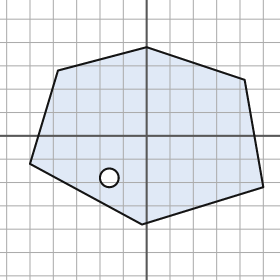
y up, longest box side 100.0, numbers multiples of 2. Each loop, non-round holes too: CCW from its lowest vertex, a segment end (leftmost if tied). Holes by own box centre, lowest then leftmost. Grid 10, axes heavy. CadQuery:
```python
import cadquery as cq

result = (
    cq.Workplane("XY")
    .moveTo(-2.0, -38.0)
    .lineTo(50.0, -22.0)
    .lineTo(42.0, 24.0)
    .lineTo(0.0, 38.0)
    .lineTo(-38.0, 28.0)
    .lineTo(-50.0, -12.0)
    .close()
    .moveTo(-16.0, -18.0)
    .circle(4.0)
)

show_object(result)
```